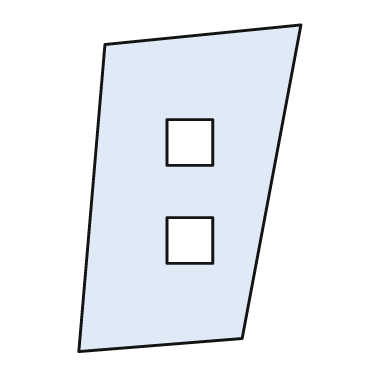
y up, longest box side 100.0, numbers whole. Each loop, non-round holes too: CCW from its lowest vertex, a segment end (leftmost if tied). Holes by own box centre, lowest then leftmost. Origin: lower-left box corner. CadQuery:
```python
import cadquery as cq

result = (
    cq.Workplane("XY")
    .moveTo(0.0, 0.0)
    .lineTo(50.0, 4.0)
    .lineTo(68.0, 100.0)
    .lineTo(8.0, 94.0)
    .close()
    .moveTo(27.0, 27.0)
    .lineTo(41.0, 27.0)
    .lineTo(41.0, 41.0)
    .lineTo(27.0, 41.0)
    .close()
    .moveTo(27.0, 57.0)
    .lineTo(41.0, 57.0)
    .lineTo(41.0, 71.0)
    .lineTo(27.0, 71.0)
    .close()
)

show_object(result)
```